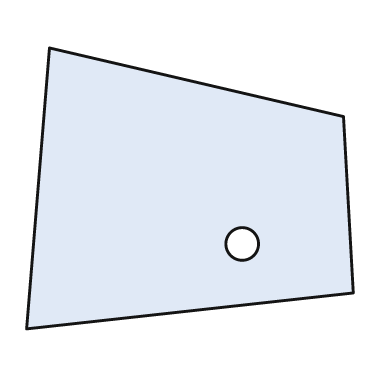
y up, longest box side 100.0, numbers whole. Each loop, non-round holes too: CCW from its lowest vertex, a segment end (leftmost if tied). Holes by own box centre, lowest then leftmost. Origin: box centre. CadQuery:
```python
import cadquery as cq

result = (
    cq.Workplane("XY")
    .moveTo(-50.0, -43.0)
    .lineTo(50.0, -32.0)
    .lineTo(47.0, 22.0)
    .lineTo(-43.0, 43.0)
    .close()
    .moveTo(16.0, -17.0)
    .circle(5.0)
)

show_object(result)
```